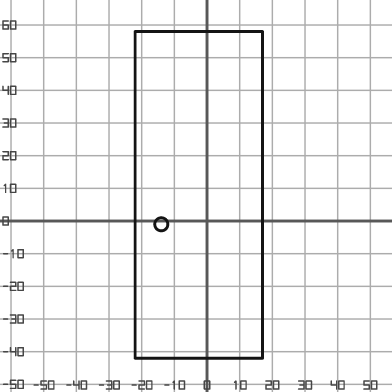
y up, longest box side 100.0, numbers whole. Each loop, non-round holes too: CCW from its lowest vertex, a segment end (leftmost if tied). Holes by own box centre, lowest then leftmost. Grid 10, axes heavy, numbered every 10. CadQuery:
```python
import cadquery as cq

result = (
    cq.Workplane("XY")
    .moveTo(-22.0, -42.0)
    .lineTo(17.0, -42.0)
    .lineTo(17.0, 58.0)
    .lineTo(-22.0, 58.0)
    .close()
    .moveTo(-14.0, -1.0)
    .circle(2.0)
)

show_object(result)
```